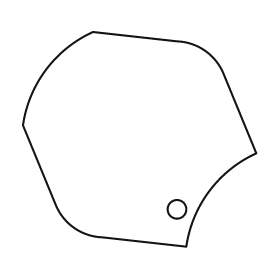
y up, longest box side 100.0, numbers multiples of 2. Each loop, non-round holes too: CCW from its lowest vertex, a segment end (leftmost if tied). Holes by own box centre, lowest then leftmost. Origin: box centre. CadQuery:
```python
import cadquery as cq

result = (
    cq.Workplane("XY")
    .moveTo(20.0, -46.0)
    .threePointArc((30.0, -22.0), (50.0, -6.0))
    .lineTo(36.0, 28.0)
    .threePointArc((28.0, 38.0), (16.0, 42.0))
    .lineTo(-20.0, 46.0)
    .threePointArc((-40.0, 30.0), (-50.0, 6.0))
    .lineTo(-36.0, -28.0)
    .threePointArc((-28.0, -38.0), (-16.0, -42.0))
    .close()
    .moveTo(16.0, -30.0)
    .circle(4.0)
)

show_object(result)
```